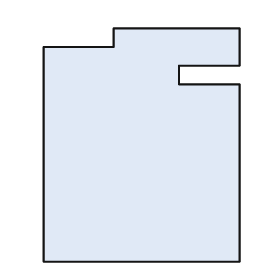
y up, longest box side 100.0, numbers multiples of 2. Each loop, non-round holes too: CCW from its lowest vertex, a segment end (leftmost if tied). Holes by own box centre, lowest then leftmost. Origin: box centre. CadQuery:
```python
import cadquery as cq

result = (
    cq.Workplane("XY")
    .moveTo(-42.0, -50.0)
    .lineTo(42.0, -50.0)
    .lineTo(42.0, 26.0)
    .lineTo(16.0, 26.0)
    .lineTo(16.0, 34.0)
    .lineTo(42.0, 34.0)
    .lineTo(42.0, 50.0)
    .lineTo(-12.0, 50.0)
    .lineTo(-12.0, 42.0)
    .lineTo(-42.0, 42.0)
    .close()
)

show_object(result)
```